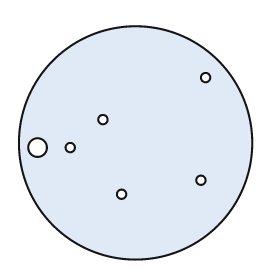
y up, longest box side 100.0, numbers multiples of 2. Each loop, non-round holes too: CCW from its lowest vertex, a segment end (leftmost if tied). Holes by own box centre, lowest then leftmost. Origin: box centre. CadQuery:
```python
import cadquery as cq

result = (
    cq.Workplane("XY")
    .moveTo(0.0, 0.0)
    .circle(50.0)
    .moveTo(-6.0, -22.0)
    .circle(2.0)
    .moveTo(28.0, -16.0)
    .circle(2.0)
    .moveTo(-42.0, -2.0)
    .circle(4.0)
    .moveTo(-28.0, -2.0)
    .circle(2.0)
    .moveTo(-14.0, 10.0)
    .circle(2.0)
    .moveTo(30.0, 28.0)
    .circle(2.0)
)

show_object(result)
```